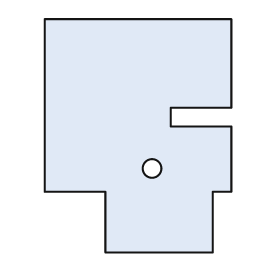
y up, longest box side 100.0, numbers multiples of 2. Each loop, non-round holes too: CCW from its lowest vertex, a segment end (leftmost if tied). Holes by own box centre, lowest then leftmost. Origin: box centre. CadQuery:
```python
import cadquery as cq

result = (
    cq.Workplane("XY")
    .moveTo(-14.0, -50.0)
    .lineTo(32.0, -50.0)
    .lineTo(32.0, -24.0)
    .lineTo(40.0, -24.0)
    .lineTo(40.0, 4.0)
    .lineTo(14.0, 4.0)
    .lineTo(14.0, 12.0)
    .lineTo(40.0, 12.0)
    .lineTo(40.0, 50.0)
    .lineTo(-40.0, 50.0)
    .lineTo(-40.0, -24.0)
    .lineTo(-14.0, -24.0)
    .close()
    .moveTo(6.0, -14.0)
    .circle(4.0)
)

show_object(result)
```